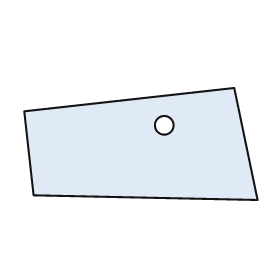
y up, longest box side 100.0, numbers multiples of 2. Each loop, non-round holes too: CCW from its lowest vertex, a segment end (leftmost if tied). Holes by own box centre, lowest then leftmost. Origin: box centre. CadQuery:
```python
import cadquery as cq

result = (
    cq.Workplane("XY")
    .moveTo(50.0, -24.0)
    .lineTo(40.0, 24.0)
    .lineTo(-50.0, 14.0)
    .lineTo(-46.0, -22.0)
    .close()
    .moveTo(10.0, 8.0)
    .circle(4.0)
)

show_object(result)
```